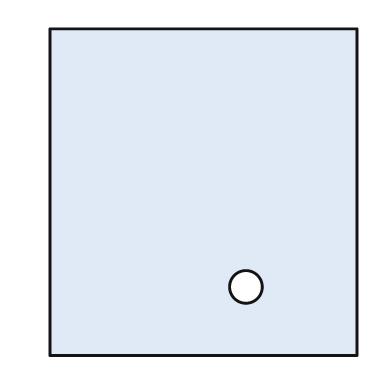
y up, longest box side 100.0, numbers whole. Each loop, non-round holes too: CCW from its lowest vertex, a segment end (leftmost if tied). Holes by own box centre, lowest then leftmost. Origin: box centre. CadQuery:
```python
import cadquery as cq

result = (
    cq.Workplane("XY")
    .moveTo(-47.0, -50.0)
    .lineTo(47.0, -50.0)
    .lineTo(47.0, 50.0)
    .lineTo(-47.0, 50.0)
    .close()
    .moveTo(13.0, -29.0)
    .circle(5.0)
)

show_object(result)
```